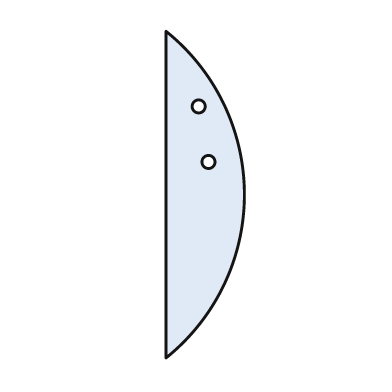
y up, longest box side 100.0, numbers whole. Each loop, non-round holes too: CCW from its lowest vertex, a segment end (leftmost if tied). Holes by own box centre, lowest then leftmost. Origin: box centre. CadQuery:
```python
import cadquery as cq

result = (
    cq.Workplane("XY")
    .moveTo(-12.0, -50.0)
    .threePointArc((12.0, 0.0), (-12.0, 50.0))
    .close()
    .moveTo(1.0, 10.0)
    .circle(2.0)
    .moveTo(-2.0, 27.0)
    .circle(2.0)
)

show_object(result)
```